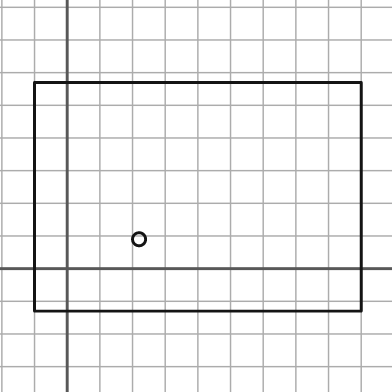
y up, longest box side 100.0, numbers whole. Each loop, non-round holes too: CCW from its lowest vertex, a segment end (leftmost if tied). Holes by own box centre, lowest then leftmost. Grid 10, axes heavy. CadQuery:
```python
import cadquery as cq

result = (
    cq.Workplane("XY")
    .moveTo(-10.0, -13.0)
    .lineTo(90.0, -13.0)
    .lineTo(90.0, 57.0)
    .lineTo(-10.0, 57.0)
    .close()
    .moveTo(22.0, 9.0)
    .circle(2.0)
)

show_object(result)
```